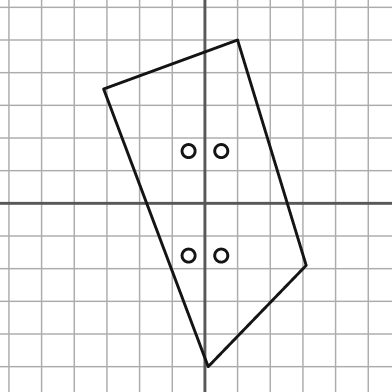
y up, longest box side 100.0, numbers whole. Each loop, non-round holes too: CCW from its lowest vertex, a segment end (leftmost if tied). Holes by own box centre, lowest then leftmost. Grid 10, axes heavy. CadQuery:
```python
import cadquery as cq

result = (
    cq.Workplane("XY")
    .moveTo(1.0, -50.0)
    .lineTo(31.0, -19.0)
    .lineTo(10.0, 50.0)
    .lineTo(-31.0, 35.0)
    .close()
    .moveTo(-5.0, -16.0)
    .circle(2.0)
    .moveTo(5.0, -16.0)
    .circle(2.0)
    .moveTo(-5.0, 16.0)
    .circle(2.0)
    .moveTo(5.0, 16.0)
    .circle(2.0)
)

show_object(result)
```